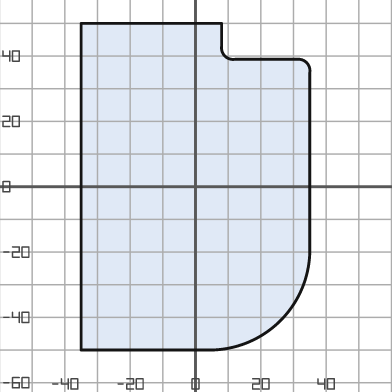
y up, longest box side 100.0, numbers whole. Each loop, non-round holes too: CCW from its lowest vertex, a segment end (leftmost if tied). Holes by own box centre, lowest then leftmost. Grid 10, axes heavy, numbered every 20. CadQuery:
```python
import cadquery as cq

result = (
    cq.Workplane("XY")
    .moveTo(-35.0, -50.0)
    .lineTo(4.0, -50.0)
    .threePointArc((26.0, -41.0), (35.0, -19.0))
    .lineTo(35.0, 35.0)
    .threePointArc((34.0, 38.0), (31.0, 39.0))
    .lineTo(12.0, 39.0)
    .threePointArc((9.0, 40.0), (8.0, 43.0))
    .lineTo(8.0, 50.0)
    .lineTo(-35.0, 50.0)
    .close()
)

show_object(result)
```